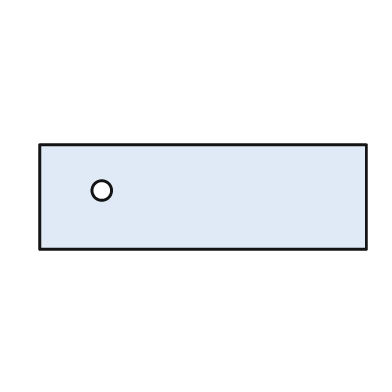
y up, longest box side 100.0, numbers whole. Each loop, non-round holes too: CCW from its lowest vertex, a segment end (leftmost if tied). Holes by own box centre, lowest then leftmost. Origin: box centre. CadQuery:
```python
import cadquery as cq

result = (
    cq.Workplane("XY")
    .moveTo(-50.0, -16.0)
    .lineTo(50.0, -16.0)
    .lineTo(50.0, 16.0)
    .lineTo(-50.0, 16.0)
    .close()
    .moveTo(-31.0, 2.0)
    .circle(3.0)
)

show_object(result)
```